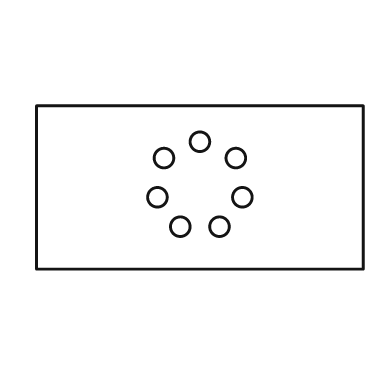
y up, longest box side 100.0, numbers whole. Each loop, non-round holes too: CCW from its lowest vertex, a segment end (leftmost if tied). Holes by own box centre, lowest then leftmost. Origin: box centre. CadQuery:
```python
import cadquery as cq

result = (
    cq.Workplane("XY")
    .moveTo(-50.0, -25.0)
    .lineTo(50.0, -25.0)
    .lineTo(50.0, 25.0)
    .lineTo(-50.0, 25.0)
    .close()
    .moveTo(-6.0, -12.0)
    .circle(3.0)
    .moveTo(6.0, -12.0)
    .circle(3.0)
    .moveTo(-13.0, -3.0)
    .circle(3.0)
    .moveTo(13.0, -3.0)
    .circle(3.0)
    .moveTo(-11.0, 9.0)
    .circle(3.0)
    .moveTo(11.0, 9.0)
    .circle(3.0)
    .moveTo(0.0, 14.0)
    .circle(3.0)
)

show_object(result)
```